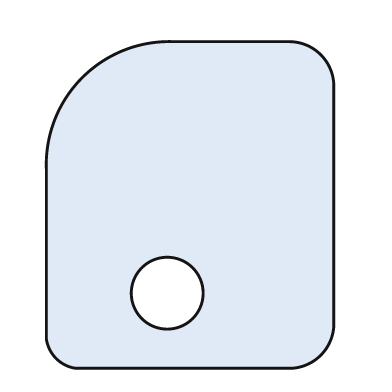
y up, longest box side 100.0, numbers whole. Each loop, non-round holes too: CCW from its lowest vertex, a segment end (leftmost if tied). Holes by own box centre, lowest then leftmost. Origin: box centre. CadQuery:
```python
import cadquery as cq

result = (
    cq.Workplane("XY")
    .moveTo(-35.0, -50.0)
    .lineTo(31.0, -50.0)
    .threePointArc((40.0, -46.0), (44.0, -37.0))
    .lineTo(44.0, 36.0)
    .threePointArc((40.0, 46.0), (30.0, 50.0))
    .lineTo(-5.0, 50.0)
    .threePointArc((-33.0, 39.0), (-44.0, 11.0))
    .lineTo(-44.0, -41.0)
    .threePointArc((-41.0, -47.0), (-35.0, -50.0))
    .close()
    .moveTo(-7.0, -27.0)
    .circle(11.0)
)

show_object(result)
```